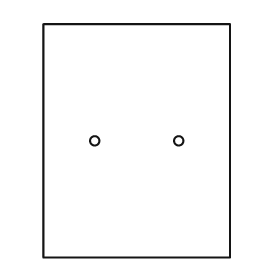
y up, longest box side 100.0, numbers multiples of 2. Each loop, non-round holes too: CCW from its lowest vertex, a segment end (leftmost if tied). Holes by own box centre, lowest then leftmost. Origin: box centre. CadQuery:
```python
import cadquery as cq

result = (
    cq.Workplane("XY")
    .moveTo(-40.0, -50.0)
    .lineTo(40.0, -50.0)
    .lineTo(40.0, 50.0)
    .lineTo(-40.0, 50.0)
    .close()
    .moveTo(-18.0, 0.0)
    .circle(2.0)
    .moveTo(18.0, 0.0)
    .circle(2.0)
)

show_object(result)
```